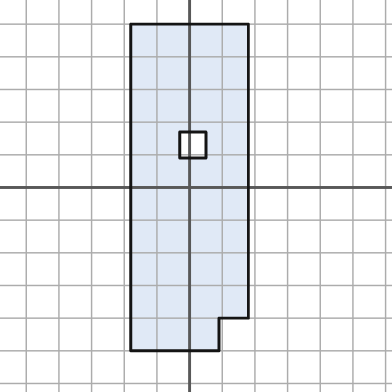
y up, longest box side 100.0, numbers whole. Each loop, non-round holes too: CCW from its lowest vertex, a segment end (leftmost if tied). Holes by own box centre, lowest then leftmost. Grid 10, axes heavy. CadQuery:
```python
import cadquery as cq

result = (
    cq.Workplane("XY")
    .moveTo(-18.0, -50.0)
    .lineTo(9.0, -50.0)
    .lineTo(9.0, -40.0)
    .lineTo(18.0, -40.0)
    .lineTo(18.0, 50.0)
    .lineTo(-18.0, 50.0)
    .close()
    .moveTo(-3.0, 9.0)
    .lineTo(5.0, 9.0)
    .lineTo(5.0, 17.0)
    .lineTo(-3.0, 17.0)
    .close()
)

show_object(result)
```